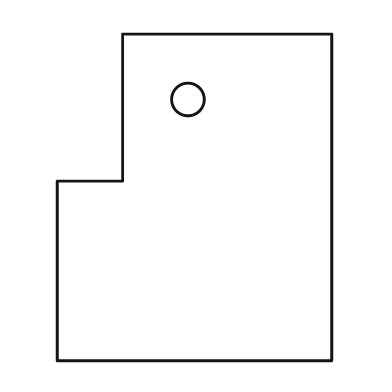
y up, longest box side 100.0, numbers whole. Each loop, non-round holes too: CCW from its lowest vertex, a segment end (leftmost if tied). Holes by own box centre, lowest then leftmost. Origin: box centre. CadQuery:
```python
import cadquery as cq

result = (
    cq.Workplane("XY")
    .moveTo(-42.0, -50.0)
    .lineTo(42.0, -50.0)
    .lineTo(42.0, 50.0)
    .lineTo(-22.0, 50.0)
    .lineTo(-22.0, 5.0)
    .lineTo(-42.0, 5.0)
    .close()
    .moveTo(-2.0, 30.0)
    .circle(5.0)
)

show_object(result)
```